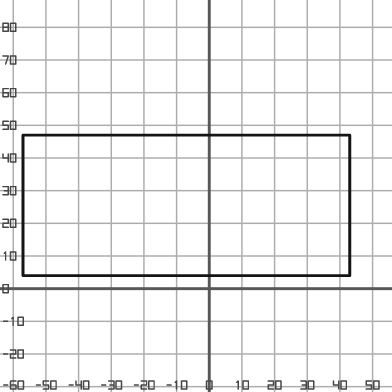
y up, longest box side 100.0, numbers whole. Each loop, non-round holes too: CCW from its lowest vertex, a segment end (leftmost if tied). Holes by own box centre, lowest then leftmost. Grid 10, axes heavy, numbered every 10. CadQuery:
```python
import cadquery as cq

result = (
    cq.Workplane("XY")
    .moveTo(-57.0, 4.0)
    .lineTo(43.0, 4.0)
    .lineTo(43.0, 47.0)
    .lineTo(-57.0, 47.0)
    .close()
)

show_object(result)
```